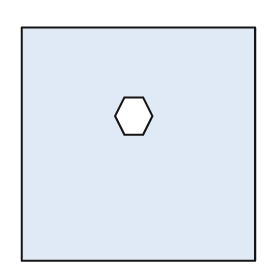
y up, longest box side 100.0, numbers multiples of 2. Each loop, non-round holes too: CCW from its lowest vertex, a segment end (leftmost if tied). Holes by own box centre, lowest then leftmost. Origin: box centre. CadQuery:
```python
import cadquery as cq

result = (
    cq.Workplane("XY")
    .moveTo(-50.0, -50.0)
    .lineTo(50.0, -50.0)
    .lineTo(50.0, 50.0)
    .lineTo(-50.0, 50.0)
    .close()
    .moveTo(-6.0, 4.0)
    .lineTo(2.0, 4.0)
    .lineTo(6.0, 12.0)
    .lineTo(2.0, 20.0)
    .lineTo(-6.0, 20.0)
    .lineTo(-10.0, 12.0)
    .close()
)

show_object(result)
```